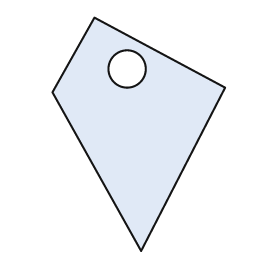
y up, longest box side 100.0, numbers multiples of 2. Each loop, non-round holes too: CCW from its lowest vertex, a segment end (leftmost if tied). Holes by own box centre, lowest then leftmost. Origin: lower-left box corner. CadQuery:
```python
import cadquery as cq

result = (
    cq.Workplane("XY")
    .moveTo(38.0, 0.0)
    .lineTo(74.0, 70.0)
    .lineTo(18.0, 100.0)
    .lineTo(0.0, 68.0)
    .close()
    .moveTo(32.0, 78.0)
    .circle(8.0)
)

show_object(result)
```